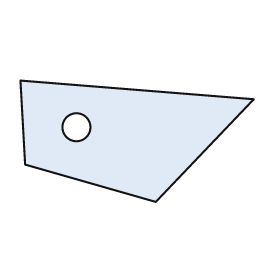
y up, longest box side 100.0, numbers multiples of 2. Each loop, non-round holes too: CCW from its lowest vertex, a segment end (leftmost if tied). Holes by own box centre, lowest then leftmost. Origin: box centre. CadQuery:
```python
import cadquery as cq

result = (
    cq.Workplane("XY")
    .moveTo(8.0, -26.0)
    .lineTo(50.0, 18.0)
    .lineTo(-50.0, 26.0)
    .lineTo(-48.0, -10.0)
    .close()
    .moveTo(-26.0, 6.0)
    .circle(6.0)
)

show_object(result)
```